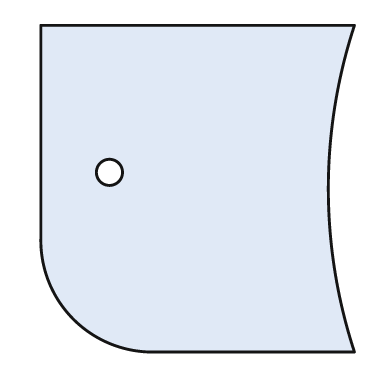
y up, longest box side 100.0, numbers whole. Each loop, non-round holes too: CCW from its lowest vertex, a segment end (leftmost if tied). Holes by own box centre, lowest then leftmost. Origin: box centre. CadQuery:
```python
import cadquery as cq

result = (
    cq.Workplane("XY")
    .moveTo(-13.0, -50.0)
    .lineTo(48.0, -50.0)
    .threePointArc((40.0, 0.0), (48.0, 50.0))
    .lineTo(-48.0, 50.0)
    .lineTo(-48.0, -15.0)
    .threePointArc((-38.0, -40.0), (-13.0, -50.0))
    .close()
    .moveTo(-27.0, 5.0)
    .circle(4.0)
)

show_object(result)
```